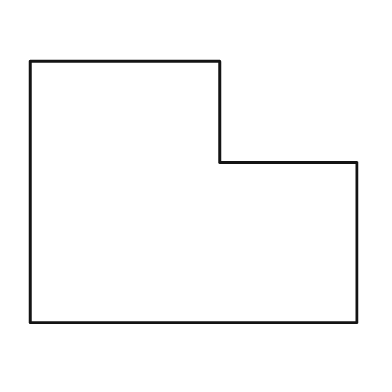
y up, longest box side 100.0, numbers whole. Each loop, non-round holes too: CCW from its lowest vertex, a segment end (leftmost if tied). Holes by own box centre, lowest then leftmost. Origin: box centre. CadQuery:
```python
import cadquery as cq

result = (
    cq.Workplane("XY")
    .moveTo(-50.0, -40.0)
    .lineTo(50.0, -40.0)
    .lineTo(50.0, 9.0)
    .lineTo(8.0, 9.0)
    .lineTo(8.0, 40.0)
    .lineTo(-50.0, 40.0)
    .close()
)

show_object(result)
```